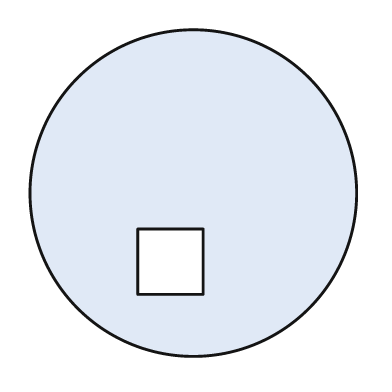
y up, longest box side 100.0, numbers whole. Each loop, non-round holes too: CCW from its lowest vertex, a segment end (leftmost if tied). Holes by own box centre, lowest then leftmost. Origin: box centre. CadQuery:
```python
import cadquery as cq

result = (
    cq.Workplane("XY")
    .moveTo(0.0, 0.0)
    .circle(50.0)
    .moveTo(-17.0, -31.0)
    .lineTo(3.0, -31.0)
    .lineTo(3.0, -11.0)
    .lineTo(-17.0, -11.0)
    .close()
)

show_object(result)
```